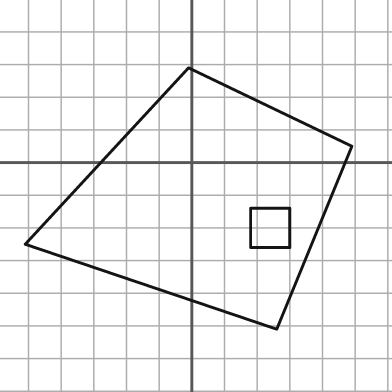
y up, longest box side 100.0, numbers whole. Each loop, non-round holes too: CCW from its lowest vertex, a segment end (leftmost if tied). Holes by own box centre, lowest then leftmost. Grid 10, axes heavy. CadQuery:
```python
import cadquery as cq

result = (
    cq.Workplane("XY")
    .moveTo(26.0, -51.0)
    .lineTo(49.0, 5.0)
    .lineTo(-1.0, 29.0)
    .lineTo(-51.0, -25.0)
    .close()
    .moveTo(18.0, -26.0)
    .lineTo(30.0, -26.0)
    .lineTo(30.0, -14.0)
    .lineTo(18.0, -14.0)
    .close()
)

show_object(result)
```